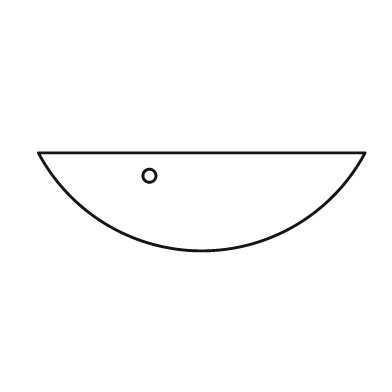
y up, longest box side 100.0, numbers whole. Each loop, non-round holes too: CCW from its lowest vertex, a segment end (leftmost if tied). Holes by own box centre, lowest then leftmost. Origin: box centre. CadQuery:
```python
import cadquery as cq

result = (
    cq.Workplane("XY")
    .moveTo(-50.0, 15.0)
    .threePointArc((0.0, -15.0), (50.0, 15.0))
    .close()
    .moveTo(-16.0, 8.0)
    .circle(2.0)
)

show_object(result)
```